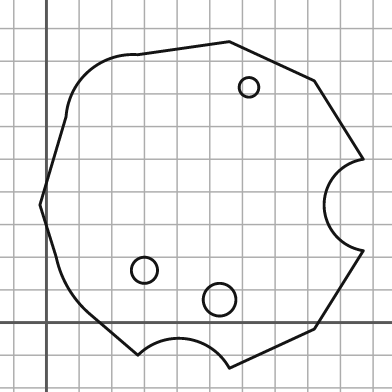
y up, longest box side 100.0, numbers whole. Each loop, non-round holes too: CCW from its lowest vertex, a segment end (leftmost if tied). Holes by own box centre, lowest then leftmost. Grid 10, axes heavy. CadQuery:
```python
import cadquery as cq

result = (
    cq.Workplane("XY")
    .moveTo(56.0, -14.0)
    .lineTo(82.0, -2.0)
    .lineTo(97.0, 22.0)
    .threePointArc((85.0, 36.0), (97.0, 50.0))
    .lineTo(82.0, 74.0)
    .lineTo(56.0, 86.0)
    .lineTo(28.0, 82.0)
    .threePointArc((13.0, 77.0), (6.0, 63.0))
    .lineTo(-2.0, 36.0)
    .lineTo(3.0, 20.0)
    .threePointArc((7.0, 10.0), (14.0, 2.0))
    .lineTo(28.0, -10.0)
    .threePointArc((43.0, -5.0), (56.0, -14.0))
    .close()
    .moveTo(53.0, 7.0)
    .circle(5.0)
    .moveTo(30.0, 16.0)
    .circle(4.0)
    .moveTo(62.0, 72.0)
    .circle(3.0)
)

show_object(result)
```